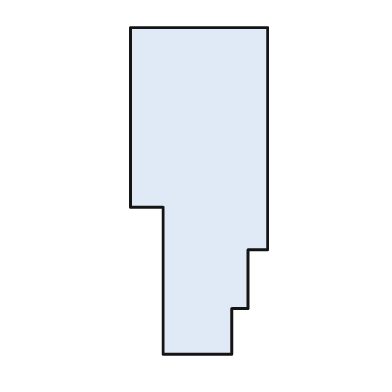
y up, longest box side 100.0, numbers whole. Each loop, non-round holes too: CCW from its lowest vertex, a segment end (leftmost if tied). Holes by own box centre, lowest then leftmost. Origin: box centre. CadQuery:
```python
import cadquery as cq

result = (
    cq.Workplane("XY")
    .moveTo(-11.0, -50.0)
    .lineTo(10.0, -50.0)
    .lineTo(10.0, -36.0)
    .lineTo(15.0, -36.0)
    .lineTo(15.0, -18.0)
    .lineTo(21.0, -18.0)
    .lineTo(21.0, 50.0)
    .lineTo(-21.0, 50.0)
    .lineTo(-21.0, -5.0)
    .lineTo(-11.0, -5.0)
    .close()
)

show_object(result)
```